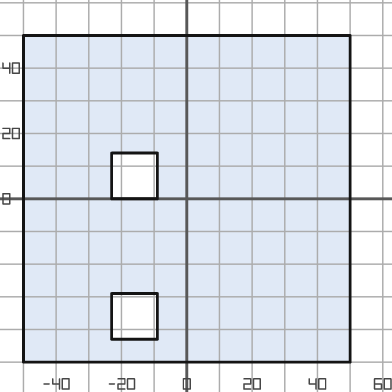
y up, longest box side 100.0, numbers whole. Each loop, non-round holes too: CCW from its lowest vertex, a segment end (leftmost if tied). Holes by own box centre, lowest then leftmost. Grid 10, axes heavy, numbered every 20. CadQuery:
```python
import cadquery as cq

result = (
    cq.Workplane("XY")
    .moveTo(-50.0, -50.0)
    .lineTo(50.0, -50.0)
    .lineTo(50.0, 50.0)
    .lineTo(-50.0, 50.0)
    .close()
    .moveTo(-23.0, -43.0)
    .lineTo(-9.0, -43.0)
    .lineTo(-9.0, -29.0)
    .lineTo(-23.0, -29.0)
    .close()
    .moveTo(-23.0, 0.0)
    .lineTo(-9.0, 0.0)
    .lineTo(-9.0, 14.0)
    .lineTo(-23.0, 14.0)
    .close()
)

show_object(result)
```